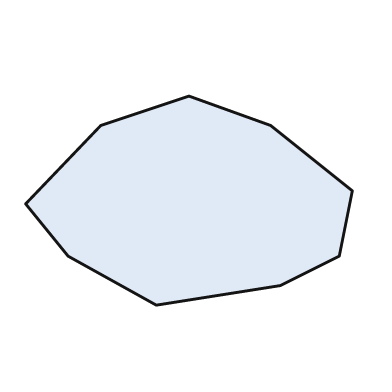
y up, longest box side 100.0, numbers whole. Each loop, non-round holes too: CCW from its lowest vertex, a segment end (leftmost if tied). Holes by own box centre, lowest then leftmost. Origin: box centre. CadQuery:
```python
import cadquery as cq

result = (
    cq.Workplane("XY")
    .moveTo(-10.0, -32.0)
    .lineTo(28.0, -26.0)
    .lineTo(46.0, -17.0)
    .lineTo(50.0, 3.0)
    .lineTo(25.0, 23.0)
    .lineTo(0.0, 32.0)
    .lineTo(-27.0, 23.0)
    .lineTo(-50.0, -1.0)
    .lineTo(-37.0, -17.0)
    .close()
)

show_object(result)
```